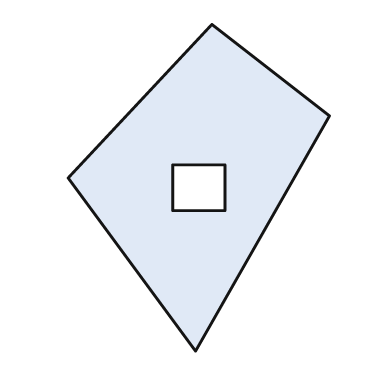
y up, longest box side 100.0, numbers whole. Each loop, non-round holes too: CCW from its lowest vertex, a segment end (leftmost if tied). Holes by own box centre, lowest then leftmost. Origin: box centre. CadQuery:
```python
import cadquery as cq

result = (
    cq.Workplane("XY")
    .moveTo(-1.0, -50.0)
    .lineTo(40.0, 22.0)
    .lineTo(4.0, 50.0)
    .lineTo(-40.0, 3.0)
    .close()
    .moveTo(-8.0, -7.0)
    .lineTo(8.0, -7.0)
    .lineTo(8.0, 7.0)
    .lineTo(-8.0, 7.0)
    .close()
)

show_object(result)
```